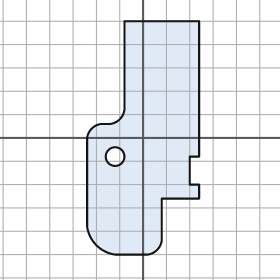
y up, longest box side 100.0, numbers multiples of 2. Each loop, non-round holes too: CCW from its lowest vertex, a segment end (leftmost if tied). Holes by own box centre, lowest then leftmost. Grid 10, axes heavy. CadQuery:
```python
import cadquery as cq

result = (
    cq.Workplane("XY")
    .moveTo(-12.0, -50.0)
    .lineTo(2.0, -50.0)
    .threePointArc((6.0, -48.0), (8.0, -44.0))
    .lineTo(8.0, -26.0)
    .lineTo(24.0, -26.0)
    .lineTo(24.0, -20.0)
    .lineTo(20.0, -20.0)
    .lineTo(20.0, -8.0)
    .lineTo(24.0, -8.0)
    .lineTo(24.0, 50.0)
    .lineTo(-8.0, 50.0)
    .lineTo(-8.0, 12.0)
    .threePointArc((-10.0, 8.0), (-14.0, 6.0))
    .lineTo(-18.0, 6.0)
    .threePointArc((-22.0, 4.0), (-24.0, 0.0))
    .lineTo(-24.0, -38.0)
    .threePointArc((-20.0, -46.0), (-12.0, -50.0))
    .close()
    .moveTo(-12.0, -8.0)
    .circle(4.0)
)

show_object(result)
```